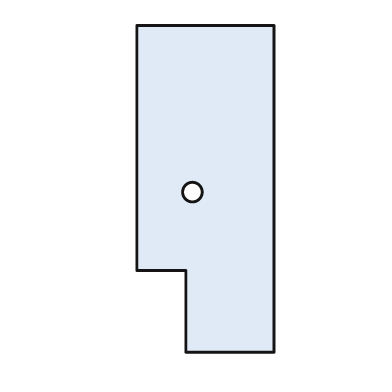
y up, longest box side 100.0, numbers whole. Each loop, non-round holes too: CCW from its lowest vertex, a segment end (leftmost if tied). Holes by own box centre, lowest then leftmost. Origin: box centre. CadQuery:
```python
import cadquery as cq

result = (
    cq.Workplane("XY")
    .moveTo(-6.0, -50.0)
    .lineTo(21.0, -50.0)
    .lineTo(21.0, 50.0)
    .lineTo(-21.0, 50.0)
    .lineTo(-21.0, -25.0)
    .lineTo(-6.0, -25.0)
    .close()
    .moveTo(-4.0, -1.0)
    .circle(3.0)
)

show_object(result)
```